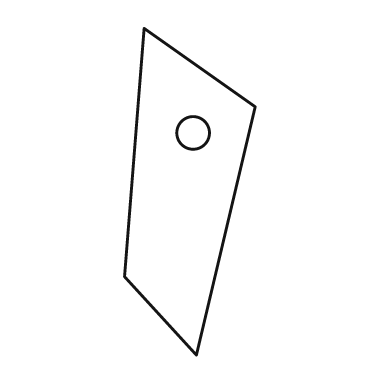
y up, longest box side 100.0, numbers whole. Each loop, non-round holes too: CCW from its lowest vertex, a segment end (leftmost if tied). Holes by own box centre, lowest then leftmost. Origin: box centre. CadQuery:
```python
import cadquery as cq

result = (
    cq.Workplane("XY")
    .moveTo(2.0, -50.0)
    .lineTo(20.0, 26.0)
    .lineTo(-14.0, 50.0)
    .lineTo(-20.0, -26.0)
    .close()
    .moveTo(1.0, 18.0)
    .circle(5.0)
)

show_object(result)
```